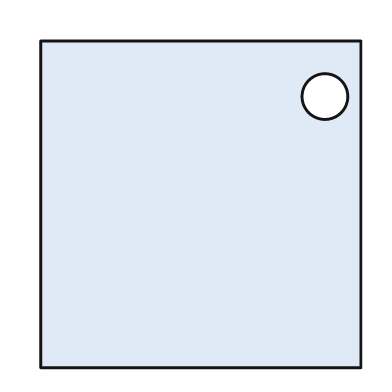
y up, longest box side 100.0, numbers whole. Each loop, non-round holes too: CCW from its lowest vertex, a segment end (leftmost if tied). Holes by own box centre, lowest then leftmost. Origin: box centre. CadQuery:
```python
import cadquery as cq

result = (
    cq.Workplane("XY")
    .moveTo(-49.0, -50.0)
    .lineTo(49.0, -50.0)
    .lineTo(49.0, 50.0)
    .lineTo(-49.0, 50.0)
    .close()
    .moveTo(38.0, 33.0)
    .circle(7.0)
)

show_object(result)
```